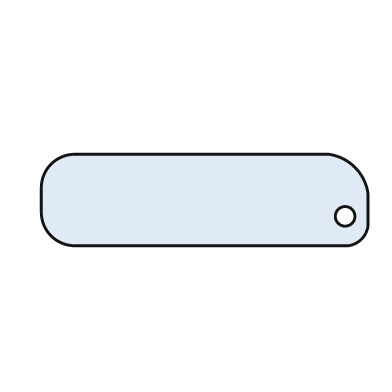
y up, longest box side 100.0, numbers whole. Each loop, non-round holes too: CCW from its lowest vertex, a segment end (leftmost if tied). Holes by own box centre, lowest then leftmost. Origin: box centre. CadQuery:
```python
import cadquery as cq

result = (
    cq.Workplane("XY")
    .moveTo(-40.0, -14.0)
    .lineTo(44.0, -14.0)
    .threePointArc((48.0, -12.0), (50.0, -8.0))
    .lineTo(50.0, 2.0)
    .threePointArc((46.0, 10.0), (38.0, 14.0))
    .lineTo(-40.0, 14.0)
    .threePointArc((-47.0, 11.0), (-50.0, 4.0))
    .lineTo(-50.0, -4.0)
    .threePointArc((-47.0, -11.0), (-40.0, -14.0))
    .close()
    .moveTo(43.0, -5.0)
    .circle(3.0)
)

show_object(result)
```